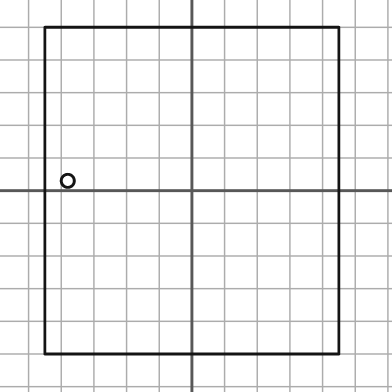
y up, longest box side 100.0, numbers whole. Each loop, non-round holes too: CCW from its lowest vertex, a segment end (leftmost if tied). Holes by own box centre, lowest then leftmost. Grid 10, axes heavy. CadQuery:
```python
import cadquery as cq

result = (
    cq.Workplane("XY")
    .moveTo(-45.0, -50.0)
    .lineTo(45.0, -50.0)
    .lineTo(45.0, 50.0)
    .lineTo(-45.0, 50.0)
    .close()
    .moveTo(-38.0, 3.0)
    .circle(2.0)
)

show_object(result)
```